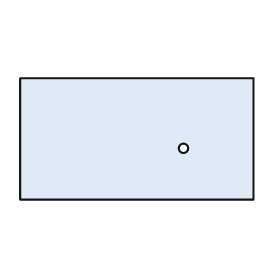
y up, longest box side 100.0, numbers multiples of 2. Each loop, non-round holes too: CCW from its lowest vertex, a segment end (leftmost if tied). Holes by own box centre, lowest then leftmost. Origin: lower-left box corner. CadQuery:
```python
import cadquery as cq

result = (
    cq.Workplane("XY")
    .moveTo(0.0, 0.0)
    .lineTo(100.0, 0.0)
    .lineTo(100.0, 52.0)
    .lineTo(0.0, 52.0)
    .close()
    .moveTo(70.0, 22.0)
    .circle(2.0)
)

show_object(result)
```